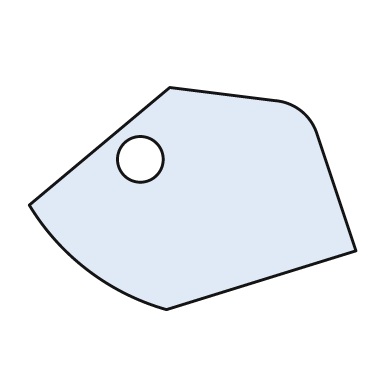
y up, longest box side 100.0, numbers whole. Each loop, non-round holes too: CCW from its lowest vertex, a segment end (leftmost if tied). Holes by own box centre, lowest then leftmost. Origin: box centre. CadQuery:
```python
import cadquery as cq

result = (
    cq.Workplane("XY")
    .moveTo(-8.0, -34.0)
    .lineTo(50.0, -16.0)
    .lineTo(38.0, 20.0)
    .threePointArc((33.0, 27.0), (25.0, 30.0))
    .lineTo(-7.0, 34.0)
    .lineTo(-50.0, -2.0)
    .threePointArc((-32.0, -22.0), (-8.0, -34.0))
    .close()
    .moveTo(-16.0, 12.0)
    .circle(7.0)
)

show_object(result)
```